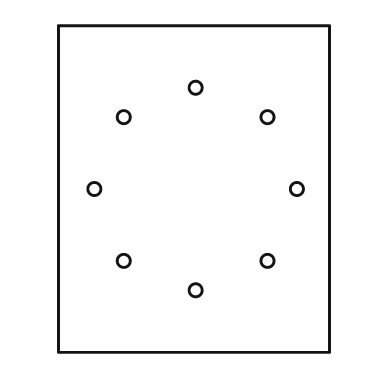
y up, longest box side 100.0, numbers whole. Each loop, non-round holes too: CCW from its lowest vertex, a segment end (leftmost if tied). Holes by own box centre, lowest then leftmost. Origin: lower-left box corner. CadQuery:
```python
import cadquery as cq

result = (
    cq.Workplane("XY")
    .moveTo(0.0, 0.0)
    .lineTo(83.0, 0.0)
    .lineTo(83.0, 100.0)
    .lineTo(0.0, 100.0)
    .close()
    .moveTo(42.0, 19.0)
    .circle(2.0)
    .moveTo(20.0, 28.0)
    .circle(2.0)
    .moveTo(64.0, 28.0)
    .circle(2.0)
    .moveTo(11.0, 50.0)
    .circle(2.0)
    .moveTo(73.0, 50.0)
    .circle(2.0)
    .moveTo(20.0, 72.0)
    .circle(2.0)
    .moveTo(64.0, 72.0)
    .circle(2.0)
    .moveTo(42.0, 81.0)
    .circle(2.0)
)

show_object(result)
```